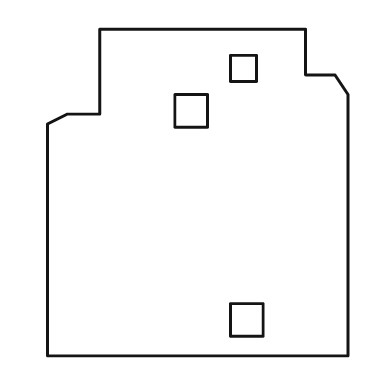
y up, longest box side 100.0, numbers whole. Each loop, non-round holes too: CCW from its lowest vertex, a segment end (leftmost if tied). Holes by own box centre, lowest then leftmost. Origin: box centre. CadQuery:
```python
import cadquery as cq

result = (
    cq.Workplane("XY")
    .moveTo(-46.0, -50.0)
    .lineTo(46.0, -50.0)
    .lineTo(46.0, 30.0)
    .lineTo(42.0, 36.0)
    .lineTo(33.0, 36.0)
    .lineTo(33.0, 50.0)
    .lineTo(-30.0, 50.0)
    .lineTo(-30.0, 24.0)
    .lineTo(-40.0, 24.0)
    .lineTo(-46.0, 21.0)
    .close()
    .moveTo(10.0, -44.0)
    .lineTo(20.0, -44.0)
    .lineTo(20.0, -34.0)
    .lineTo(10.0, -34.0)
    .close()
    .moveTo(-7.0, 20.0)
    .lineTo(3.0, 20.0)
    .lineTo(3.0, 30.0)
    .lineTo(-7.0, 30.0)
    .close()
    .moveTo(10.0, 34.0)
    .lineTo(18.0, 34.0)
    .lineTo(18.0, 42.0)
    .lineTo(10.0, 42.0)
    .close()
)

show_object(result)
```